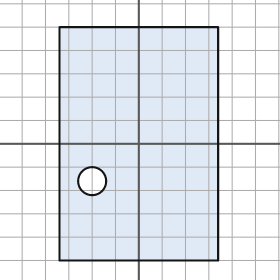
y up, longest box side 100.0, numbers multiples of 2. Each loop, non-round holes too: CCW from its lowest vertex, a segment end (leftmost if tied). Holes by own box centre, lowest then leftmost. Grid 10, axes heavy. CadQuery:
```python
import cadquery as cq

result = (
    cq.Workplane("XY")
    .moveTo(-34.0, -50.0)
    .lineTo(34.0, -50.0)
    .lineTo(34.0, 50.0)
    .lineTo(-34.0, 50.0)
    .close()
    .moveTo(-20.0, -16.0)
    .circle(6.0)
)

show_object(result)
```